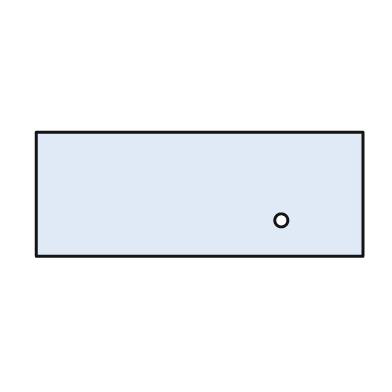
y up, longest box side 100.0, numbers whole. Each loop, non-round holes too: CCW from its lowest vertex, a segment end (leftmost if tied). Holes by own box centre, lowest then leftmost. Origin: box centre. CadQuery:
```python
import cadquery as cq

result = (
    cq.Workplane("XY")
    .moveTo(-50.0, -19.0)
    .lineTo(50.0, -19.0)
    .lineTo(50.0, 19.0)
    .lineTo(-50.0, 19.0)
    .close()
    .moveTo(25.0, -8.0)
    .circle(2.0)
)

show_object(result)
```